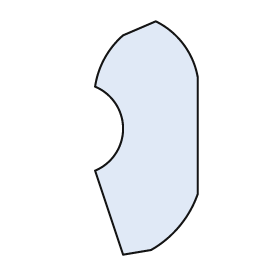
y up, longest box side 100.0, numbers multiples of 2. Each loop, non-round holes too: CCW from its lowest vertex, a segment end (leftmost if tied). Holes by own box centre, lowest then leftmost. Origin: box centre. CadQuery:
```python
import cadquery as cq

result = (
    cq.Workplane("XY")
    .moveTo(-10.0, -50.0)
    .lineTo(2.0, -48.0)
    .threePointArc((14.0, -38.0), (22.0, -24.0))
    .lineTo(22.0, 26.0)
    .threePointArc((16.0, 40.0), (4.0, 50.0))
    .lineTo(-10.0, 44.0)
    .threePointArc((-18.0, 34.0), (-22.0, 22.0))
    .threePointArc((-10.0, 4.0), (-22.0, -14.0))
    .close()
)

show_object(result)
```